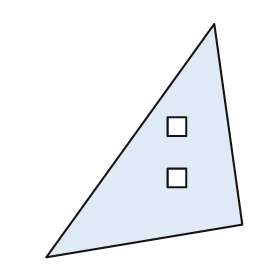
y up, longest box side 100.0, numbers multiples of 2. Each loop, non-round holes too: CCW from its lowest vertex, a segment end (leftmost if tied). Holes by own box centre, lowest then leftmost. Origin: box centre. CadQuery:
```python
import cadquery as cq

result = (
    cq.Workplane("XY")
    .moveTo(-42.0, -50.0)
    .lineTo(42.0, -36.0)
    .lineTo(30.0, 50.0)
    .close()
    .moveTo(10.0, -20.0)
    .lineTo(18.0, -20.0)
    .lineTo(18.0, -12.0)
    .lineTo(10.0, -12.0)
    .close()
    .moveTo(10.0, 2.0)
    .lineTo(18.0, 2.0)
    .lineTo(18.0, 10.0)
    .lineTo(10.0, 10.0)
    .close()
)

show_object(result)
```